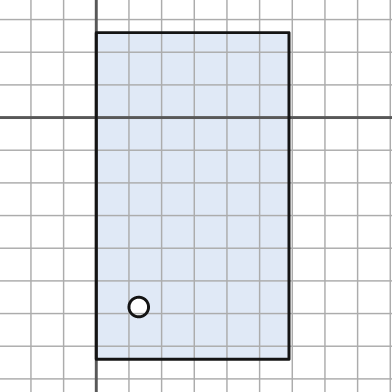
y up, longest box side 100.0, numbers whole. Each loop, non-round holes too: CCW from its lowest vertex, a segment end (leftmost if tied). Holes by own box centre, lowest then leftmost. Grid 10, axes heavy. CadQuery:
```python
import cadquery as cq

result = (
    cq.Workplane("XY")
    .moveTo(0.0, -74.0)
    .lineTo(59.0, -74.0)
    .lineTo(59.0, 26.0)
    .lineTo(0.0, 26.0)
    .close()
    .moveTo(13.0, -58.0)
    .circle(3.0)
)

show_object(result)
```